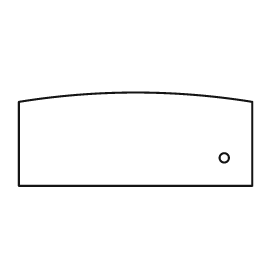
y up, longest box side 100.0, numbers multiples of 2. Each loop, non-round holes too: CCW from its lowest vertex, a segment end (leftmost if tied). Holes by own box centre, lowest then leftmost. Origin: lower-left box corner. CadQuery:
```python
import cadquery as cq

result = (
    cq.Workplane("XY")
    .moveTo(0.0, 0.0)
    .lineTo(100.0, 0.0)
    .lineTo(100.0, 36.0)
    .threePointArc((50.0, 40.0), (0.0, 36.0))
    .close()
    .moveTo(88.0, 12.0)
    .circle(2.0)
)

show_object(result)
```